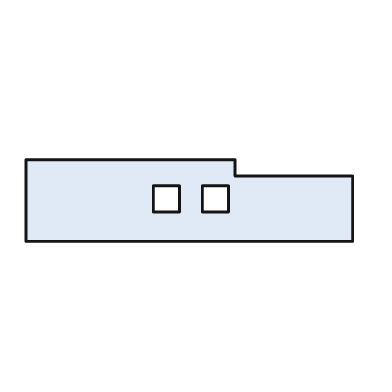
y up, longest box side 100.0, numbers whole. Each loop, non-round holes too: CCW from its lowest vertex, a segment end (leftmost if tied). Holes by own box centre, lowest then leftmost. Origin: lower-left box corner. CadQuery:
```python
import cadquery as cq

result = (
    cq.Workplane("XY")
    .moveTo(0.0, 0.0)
    .lineTo(100.0, 0.0)
    .lineTo(100.0, 20.0)
    .lineTo(64.0, 20.0)
    .lineTo(64.0, 25.0)
    .lineTo(0.0, 25.0)
    .close()
    .moveTo(39.0, 9.0)
    .lineTo(47.0, 9.0)
    .lineTo(47.0, 17.0)
    .lineTo(39.0, 17.0)
    .close()
    .moveTo(54.0, 9.0)
    .lineTo(62.0, 9.0)
    .lineTo(62.0, 17.0)
    .lineTo(54.0, 17.0)
    .close()
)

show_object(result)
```